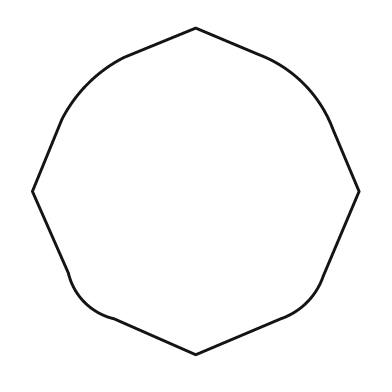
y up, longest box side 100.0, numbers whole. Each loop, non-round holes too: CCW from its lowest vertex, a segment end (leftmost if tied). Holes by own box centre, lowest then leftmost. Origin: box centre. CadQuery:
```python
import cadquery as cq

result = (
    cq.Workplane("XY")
    .moveTo(0.0, -50.0)
    .lineTo(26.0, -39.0)
    .threePointArc((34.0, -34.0), (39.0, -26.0))
    .lineTo(50.0, 0.0)
    .lineTo(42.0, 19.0)
    .threePointArc((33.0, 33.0), (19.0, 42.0))
    .lineTo(0.0, 50.0)
    .lineTo(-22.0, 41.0)
    .threePointArc((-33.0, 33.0), (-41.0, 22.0))
    .lineTo(-50.0, 0.0)
    .lineTo(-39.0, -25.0)
    .threePointArc((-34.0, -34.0), (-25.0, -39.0))
    .close()
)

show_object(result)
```